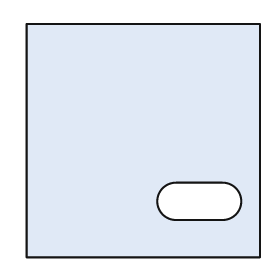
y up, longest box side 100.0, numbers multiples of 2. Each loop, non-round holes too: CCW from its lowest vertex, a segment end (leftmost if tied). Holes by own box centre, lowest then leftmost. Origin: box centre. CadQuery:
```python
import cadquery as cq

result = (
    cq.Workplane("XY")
    .moveTo(-50.0, -50.0)
    .lineTo(50.0, -50.0)
    .lineTo(50.0, 50.0)
    .lineTo(-50.0, 50.0)
    .close()
    .moveTo(14.0, -34.0)
    .lineTo(34.0, -34.0)
    .threePointArc((42.0, -26.0), (34.0, -18.0))
    .lineTo(14.0, -18.0)
    .threePointArc((6.0, -26.0), (14.0, -34.0))
    .close()
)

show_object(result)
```